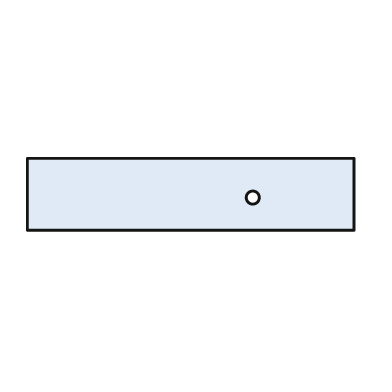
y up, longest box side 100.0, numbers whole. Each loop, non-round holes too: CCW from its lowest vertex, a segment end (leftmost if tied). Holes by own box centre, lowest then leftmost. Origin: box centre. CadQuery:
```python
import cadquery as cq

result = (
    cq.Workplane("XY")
    .moveTo(-50.0, -11.0)
    .lineTo(50.0, -11.0)
    .lineTo(50.0, 11.0)
    .lineTo(-50.0, 11.0)
    .close()
    .moveTo(19.0, -1.0)
    .circle(2.0)
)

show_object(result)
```